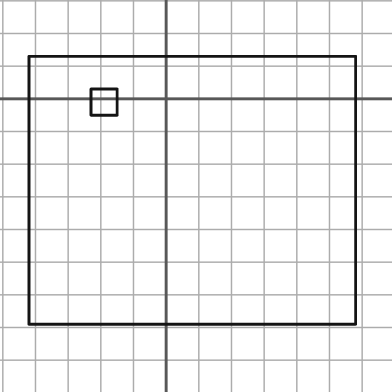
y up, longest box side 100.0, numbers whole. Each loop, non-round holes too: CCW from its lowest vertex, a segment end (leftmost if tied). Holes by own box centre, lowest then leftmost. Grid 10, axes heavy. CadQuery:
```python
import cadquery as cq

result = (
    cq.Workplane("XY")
    .moveTo(-42.0, -69.0)
    .lineTo(58.0, -69.0)
    .lineTo(58.0, 13.0)
    .lineTo(-42.0, 13.0)
    .close()
    .moveTo(-23.0, -5.0)
    .lineTo(-15.0, -5.0)
    .lineTo(-15.0, 3.0)
    .lineTo(-23.0, 3.0)
    .close()
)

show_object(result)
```